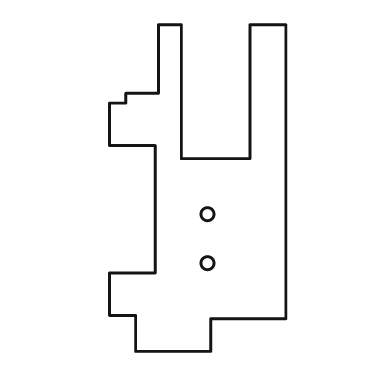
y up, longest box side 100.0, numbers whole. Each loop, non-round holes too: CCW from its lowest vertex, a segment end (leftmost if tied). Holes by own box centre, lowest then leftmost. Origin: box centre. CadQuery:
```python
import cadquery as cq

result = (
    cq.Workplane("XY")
    .moveTo(-19.0, -50.0)
    .lineTo(4.0, -50.0)
    .lineTo(4.0, -40.0)
    .lineTo(27.0, -40.0)
    .lineTo(27.0, 50.0)
    .lineTo(16.0, 50.0)
    .lineTo(16.0, 9.0)
    .lineTo(-5.0, 9.0)
    .lineTo(-5.0, 50.0)
    .lineTo(-12.0, 50.0)
    .lineTo(-12.0, 29.0)
    .lineTo(-22.0, 29.0)
    .lineTo(-22.0, 26.0)
    .lineTo(-27.0, 26.0)
    .lineTo(-27.0, 13.0)
    .lineTo(-13.0, 13.0)
    .lineTo(-13.0, -26.0)
    .lineTo(-27.0, -26.0)
    .lineTo(-27.0, -39.0)
    .lineTo(-19.0, -39.0)
    .close()
    .moveTo(3.0, -23.0)
    .circle(2.0)
    .moveTo(3.0, -8.0)
    .circle(2.0)
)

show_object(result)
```